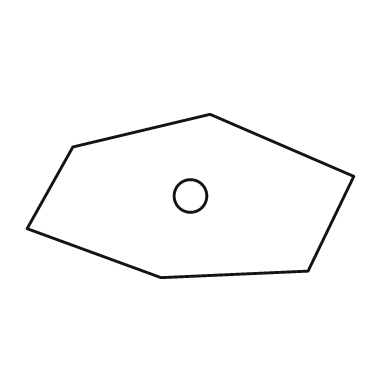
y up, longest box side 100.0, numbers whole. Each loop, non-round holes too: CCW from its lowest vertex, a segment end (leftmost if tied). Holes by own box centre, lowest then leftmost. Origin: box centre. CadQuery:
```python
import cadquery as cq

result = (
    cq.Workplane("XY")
    .moveTo(-9.0, -25.0)
    .lineTo(36.0, -23.0)
    .lineTo(50.0, 6.0)
    .lineTo(6.0, 25.0)
    .lineTo(-36.0, 15.0)
    .lineTo(-50.0, -10.0)
    .close()
    .moveTo(0.0, 0.0)
    .circle(5.0)
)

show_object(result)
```